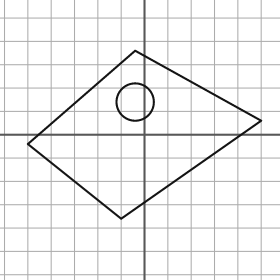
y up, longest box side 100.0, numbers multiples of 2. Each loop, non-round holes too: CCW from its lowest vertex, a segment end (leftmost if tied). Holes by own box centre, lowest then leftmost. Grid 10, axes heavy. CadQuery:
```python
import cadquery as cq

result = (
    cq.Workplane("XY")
    .moveTo(-10.0, -36.0)
    .lineTo(50.0, 6.0)
    .lineTo(-4.0, 36.0)
    .lineTo(-50.0, -4.0)
    .close()
    .moveTo(-4.0, 14.0)
    .circle(8.0)
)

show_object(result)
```